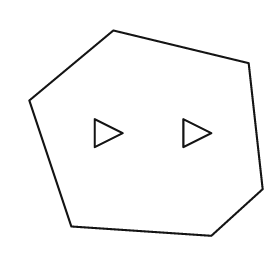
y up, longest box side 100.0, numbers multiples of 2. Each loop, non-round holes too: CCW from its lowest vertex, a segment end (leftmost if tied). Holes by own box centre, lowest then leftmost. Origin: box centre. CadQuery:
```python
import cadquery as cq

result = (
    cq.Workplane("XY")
    .moveTo(28.0, -44.0)
    .lineTo(50.0, -24.0)
    .lineTo(44.0, 30.0)
    .lineTo(-14.0, 44.0)
    .lineTo(-50.0, 14.0)
    .lineTo(-32.0, -40.0)
    .close()
    .moveTo(-22.0, -6.0)
    .lineTo(-10.0, 0.0)
    .lineTo(-22.0, 6.0)
    .close()
    .moveTo(16.0, -6.0)
    .lineTo(28.0, 0.0)
    .lineTo(16.0, 6.0)
    .close()
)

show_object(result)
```